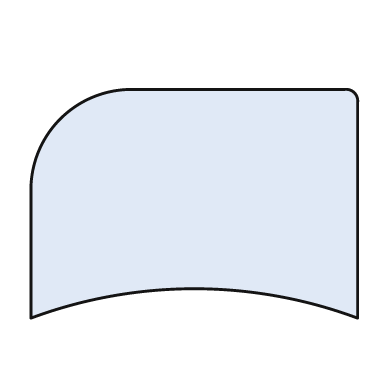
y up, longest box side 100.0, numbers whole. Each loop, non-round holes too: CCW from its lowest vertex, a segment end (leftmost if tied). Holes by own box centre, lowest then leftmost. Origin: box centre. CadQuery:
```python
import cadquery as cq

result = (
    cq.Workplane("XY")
    .moveTo(-50.0, -35.0)
    .threePointArc((0.0, -26.0), (50.0, -35.0))
    .lineTo(50.0, 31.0)
    .threePointArc((49.0, 34.0), (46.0, 35.0))
    .lineTo(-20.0, 35.0)
    .threePointArc((-41.0, 26.0), (-50.0, 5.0))
    .close()
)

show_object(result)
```